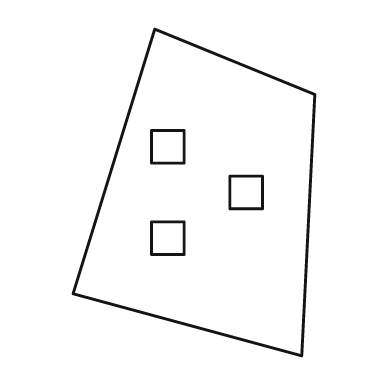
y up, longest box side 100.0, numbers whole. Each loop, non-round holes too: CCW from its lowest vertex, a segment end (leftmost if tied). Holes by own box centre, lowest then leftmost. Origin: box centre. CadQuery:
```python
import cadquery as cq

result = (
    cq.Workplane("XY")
    .moveTo(33.0, -50.0)
    .lineTo(37.0, 30.0)
    .lineTo(-12.0, 50.0)
    .lineTo(-37.0, -31.0)
    .close()
    .moveTo(-13.0, -19.0)
    .lineTo(-3.0, -19.0)
    .lineTo(-3.0, -9.0)
    .lineTo(-13.0, -9.0)
    .close()
    .moveTo(11.0, -5.0)
    .lineTo(21.0, -5.0)
    .lineTo(21.0, 5.0)
    .lineTo(11.0, 5.0)
    .close()
    .moveTo(-13.0, 9.0)
    .lineTo(-3.0, 9.0)
    .lineTo(-3.0, 19.0)
    .lineTo(-13.0, 19.0)
    .close()
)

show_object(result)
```